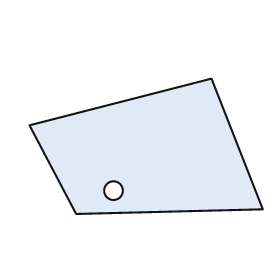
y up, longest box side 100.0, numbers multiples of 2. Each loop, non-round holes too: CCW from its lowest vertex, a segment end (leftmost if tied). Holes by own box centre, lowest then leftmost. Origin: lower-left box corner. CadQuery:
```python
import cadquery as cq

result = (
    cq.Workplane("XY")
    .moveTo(20.0, 0.0)
    .lineTo(100.0, 2.0)
    .lineTo(78.0, 58.0)
    .lineTo(0.0, 38.0)
    .close()
    .moveTo(36.0, 10.0)
    .circle(4.0)
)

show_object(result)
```